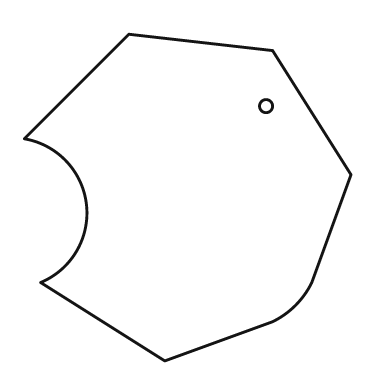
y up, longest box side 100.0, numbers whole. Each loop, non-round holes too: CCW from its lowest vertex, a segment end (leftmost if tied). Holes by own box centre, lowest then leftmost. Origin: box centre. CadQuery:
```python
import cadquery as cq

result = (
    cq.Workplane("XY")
    .moveTo(-7.0, -50.0)
    .lineTo(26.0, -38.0)
    .threePointArc((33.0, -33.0), (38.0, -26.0))
    .lineTo(50.0, 7.0)
    .lineTo(26.0, 45.0)
    .lineTo(-18.0, 50.0)
    .lineTo(-50.0, 18.0)
    .threePointArc((-31.0, -2.0), (-45.0, -26.0))
    .close()
    .moveTo(24.0, 28.0)
    .circle(2.0)
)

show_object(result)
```